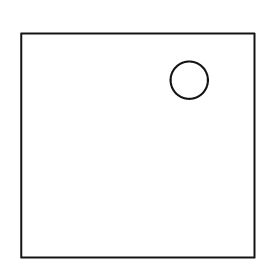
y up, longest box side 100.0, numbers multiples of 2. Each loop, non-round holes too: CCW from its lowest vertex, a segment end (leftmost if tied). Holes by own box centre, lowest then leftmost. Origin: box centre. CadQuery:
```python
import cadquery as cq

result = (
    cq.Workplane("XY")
    .moveTo(-50.0, -48.0)
    .lineTo(50.0, -48.0)
    .lineTo(50.0, 48.0)
    .lineTo(-50.0, 48.0)
    .close()
    .moveTo(22.0, 28.0)
    .circle(8.0)
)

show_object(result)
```